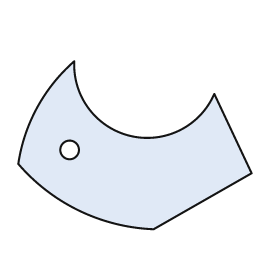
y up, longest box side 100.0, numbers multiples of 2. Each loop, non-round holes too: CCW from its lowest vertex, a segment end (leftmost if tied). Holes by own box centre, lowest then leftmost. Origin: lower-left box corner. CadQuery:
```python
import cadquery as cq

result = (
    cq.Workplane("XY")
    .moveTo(58.0, 0.0)
    .lineTo(100.0, 24.0)
    .lineTo(84.0, 58.0)
    .threePointArc((48.0, 40.0), (24.0, 72.0))
    .threePointArc((8.0, 52.0), (0.0, 28.0))
    .threePointArc((26.0, 8.0), (58.0, 0.0))
    .close()
    .moveTo(22.0, 34.0)
    .circle(4.0)
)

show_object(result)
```